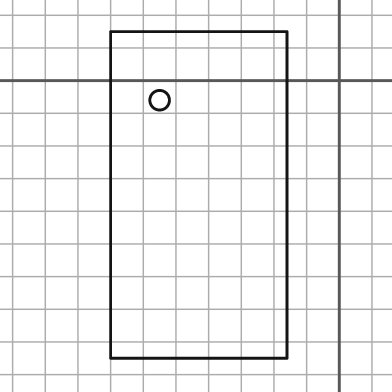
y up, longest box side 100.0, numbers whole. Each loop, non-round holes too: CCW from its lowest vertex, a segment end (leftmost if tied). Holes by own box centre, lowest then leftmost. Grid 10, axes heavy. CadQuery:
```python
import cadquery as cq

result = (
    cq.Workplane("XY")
    .moveTo(-70.0, -85.0)
    .lineTo(-16.0, -85.0)
    .lineTo(-16.0, 15.0)
    .lineTo(-70.0, 15.0)
    .close()
    .moveTo(-55.0, -6.0)
    .circle(3.0)
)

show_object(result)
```